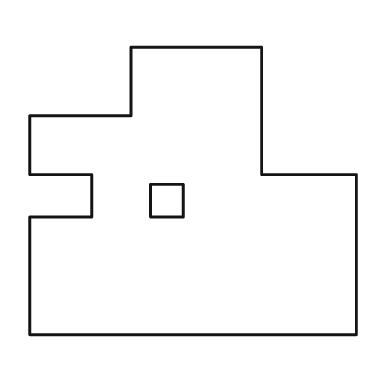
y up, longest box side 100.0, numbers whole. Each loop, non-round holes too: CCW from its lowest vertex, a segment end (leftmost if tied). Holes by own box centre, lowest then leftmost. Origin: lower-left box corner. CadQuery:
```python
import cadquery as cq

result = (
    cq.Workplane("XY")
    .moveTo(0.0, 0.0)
    .lineTo(100.0, 0.0)
    .lineTo(100.0, 49.0)
    .lineTo(71.0, 49.0)
    .lineTo(71.0, 88.0)
    .lineTo(31.0, 88.0)
    .lineTo(31.0, 67.0)
    .lineTo(0.0, 67.0)
    .lineTo(0.0, 49.0)
    .lineTo(19.0, 49.0)
    .lineTo(19.0, 36.0)
    .lineTo(0.0, 36.0)
    .close()
    .moveTo(37.0, 36.0)
    .lineTo(47.0, 36.0)
    .lineTo(47.0, 46.0)
    .lineTo(37.0, 46.0)
    .close()
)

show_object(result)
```